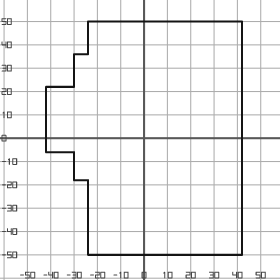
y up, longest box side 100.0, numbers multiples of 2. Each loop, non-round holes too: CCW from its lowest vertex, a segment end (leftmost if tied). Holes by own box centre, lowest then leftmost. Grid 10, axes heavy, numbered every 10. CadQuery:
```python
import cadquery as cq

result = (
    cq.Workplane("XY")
    .moveTo(-24.0, -50.0)
    .lineTo(42.0, -50.0)
    .lineTo(42.0, 50.0)
    .lineTo(-24.0, 50.0)
    .lineTo(-24.0, 36.0)
    .lineTo(-30.0, 36.0)
    .lineTo(-30.0, 22.0)
    .lineTo(-42.0, 22.0)
    .lineTo(-42.0, -6.0)
    .lineTo(-30.0, -6.0)
    .lineTo(-30.0, -18.0)
    .lineTo(-24.0, -18.0)
    .close()
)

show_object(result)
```